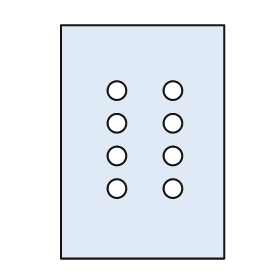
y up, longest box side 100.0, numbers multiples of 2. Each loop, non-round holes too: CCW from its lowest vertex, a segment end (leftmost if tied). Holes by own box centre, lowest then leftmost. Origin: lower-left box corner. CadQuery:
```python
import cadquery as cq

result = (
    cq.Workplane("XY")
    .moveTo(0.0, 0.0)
    .lineTo(70.0, 0.0)
    .lineTo(70.0, 100.0)
    .lineTo(0.0, 100.0)
    .close()
    .moveTo(24.0, 30.0)
    .circle(4.0)
    .moveTo(48.0, 30.0)
    .circle(4.0)
    .moveTo(24.0, 44.0)
    .circle(4.0)
    .moveTo(48.0, 44.0)
    .circle(4.0)
    .moveTo(24.0, 58.0)
    .circle(4.0)
    .moveTo(48.0, 58.0)
    .circle(4.0)
    .moveTo(24.0, 72.0)
    .circle(4.0)
    .moveTo(48.0, 72.0)
    .circle(4.0)
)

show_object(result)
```